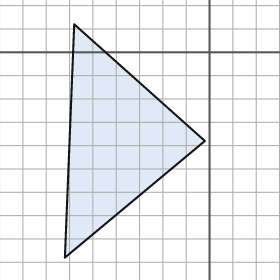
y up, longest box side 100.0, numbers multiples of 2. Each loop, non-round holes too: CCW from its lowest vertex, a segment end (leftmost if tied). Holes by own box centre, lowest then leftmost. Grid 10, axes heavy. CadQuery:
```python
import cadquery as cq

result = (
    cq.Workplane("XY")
    .moveTo(-62.0, -88.0)
    .lineTo(-2.0, -38.0)
    .lineTo(-58.0, 12.0)
    .close()
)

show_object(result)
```